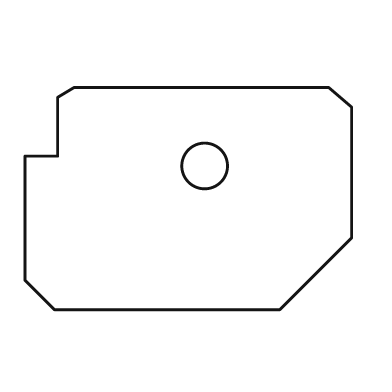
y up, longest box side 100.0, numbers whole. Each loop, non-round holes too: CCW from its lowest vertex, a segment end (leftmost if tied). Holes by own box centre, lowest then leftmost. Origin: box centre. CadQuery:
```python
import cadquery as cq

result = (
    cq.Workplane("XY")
    .moveTo(-41.0, -34.0)
    .lineTo(28.0, -34.0)
    .lineTo(50.0, -12.0)
    .lineTo(50.0, 28.0)
    .lineTo(43.0, 34.0)
    .lineTo(-35.0, 34.0)
    .lineTo(-40.0, 31.0)
    .lineTo(-40.0, 13.0)
    .lineTo(-50.0, 13.0)
    .lineTo(-50.0, -25.0)
    .close()
    .moveTo(5.0, 10.0)
    .circle(7.0)
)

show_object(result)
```